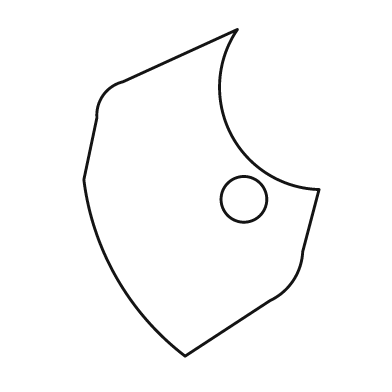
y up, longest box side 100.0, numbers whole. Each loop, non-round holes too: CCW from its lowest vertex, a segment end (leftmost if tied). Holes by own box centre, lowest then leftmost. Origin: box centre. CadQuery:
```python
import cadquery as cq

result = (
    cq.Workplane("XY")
    .moveTo(-5.0, -50.0)
    .lineTo(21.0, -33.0)
    .threePointArc((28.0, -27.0), (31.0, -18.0))
    .lineTo(36.0, 1.0)
    .threePointArc((9.0, 18.0), (11.0, 50.0))
    .lineTo(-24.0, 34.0)
    .threePointArc((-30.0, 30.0), (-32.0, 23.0))
    .lineTo(-36.0, 4.0)
    .threePointArc((-26.0, -26.0), (-5.0, -50.0))
    .close()
    .moveTo(13.0, -2.0)
    .circle(7.0)
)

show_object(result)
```